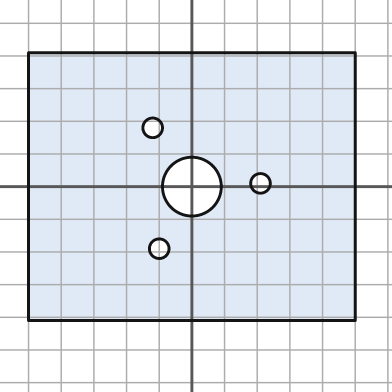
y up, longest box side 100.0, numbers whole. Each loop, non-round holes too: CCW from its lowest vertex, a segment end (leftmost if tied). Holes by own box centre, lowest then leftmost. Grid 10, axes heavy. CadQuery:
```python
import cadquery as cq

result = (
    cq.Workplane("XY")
    .moveTo(-50.0, -41.0)
    .lineTo(50.0, -41.0)
    .lineTo(50.0, 41.0)
    .lineTo(-50.0, 41.0)
    .close()
    .moveTo(-10.0, -19.0)
    .circle(3.0)
    .moveTo(0.0, 0.0)
    .circle(9.0)
    .moveTo(21.0, 1.0)
    .circle(3.0)
    .moveTo(-12.0, 18.0)
    .circle(3.0)
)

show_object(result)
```